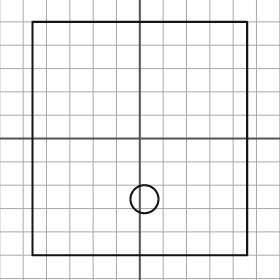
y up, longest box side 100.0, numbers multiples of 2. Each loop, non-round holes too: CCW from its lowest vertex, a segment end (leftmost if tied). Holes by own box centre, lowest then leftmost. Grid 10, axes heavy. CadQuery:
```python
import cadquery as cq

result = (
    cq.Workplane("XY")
    .moveTo(-46.0, -50.0)
    .lineTo(46.0, -50.0)
    .lineTo(46.0, 50.0)
    .lineTo(-46.0, 50.0)
    .close()
    .moveTo(2.0, -26.0)
    .circle(6.0)
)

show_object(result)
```